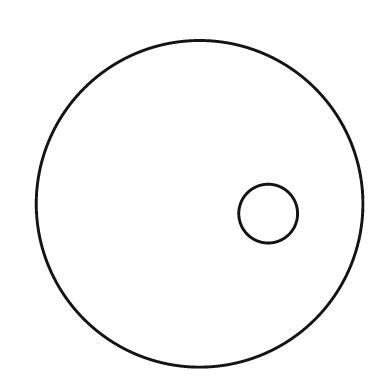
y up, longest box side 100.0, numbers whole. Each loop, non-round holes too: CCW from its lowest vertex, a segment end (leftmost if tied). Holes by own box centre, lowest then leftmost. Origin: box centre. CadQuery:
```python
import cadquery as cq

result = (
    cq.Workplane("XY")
    .moveTo(0.0, 0.0)
    .circle(50.0)
    .moveTo(21.0, -3.0)
    .circle(9.0)
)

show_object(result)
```